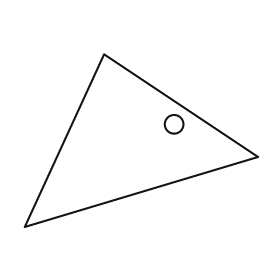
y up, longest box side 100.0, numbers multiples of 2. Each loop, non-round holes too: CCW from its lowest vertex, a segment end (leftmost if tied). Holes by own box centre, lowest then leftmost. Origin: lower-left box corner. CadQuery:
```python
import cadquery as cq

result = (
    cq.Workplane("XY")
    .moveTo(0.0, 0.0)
    .lineTo(100.0, 30.0)
    .lineTo(34.0, 74.0)
    .close()
    .moveTo(64.0, 44.0)
    .circle(4.0)
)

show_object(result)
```